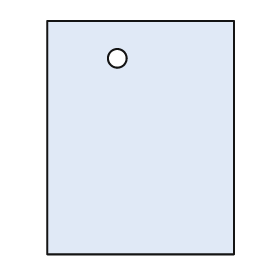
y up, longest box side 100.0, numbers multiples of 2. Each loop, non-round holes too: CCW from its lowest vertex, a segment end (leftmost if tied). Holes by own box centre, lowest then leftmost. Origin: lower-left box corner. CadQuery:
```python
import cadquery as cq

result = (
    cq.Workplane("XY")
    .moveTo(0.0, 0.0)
    .lineTo(80.0, 0.0)
    .lineTo(80.0, 100.0)
    .lineTo(0.0, 100.0)
    .close()
    .moveTo(30.0, 84.0)
    .circle(4.0)
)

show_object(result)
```